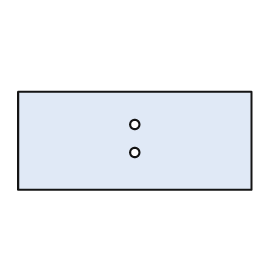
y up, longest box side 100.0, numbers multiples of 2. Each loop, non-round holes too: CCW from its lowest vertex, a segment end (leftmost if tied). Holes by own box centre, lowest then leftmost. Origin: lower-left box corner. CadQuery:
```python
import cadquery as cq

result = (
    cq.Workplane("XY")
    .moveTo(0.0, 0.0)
    .lineTo(100.0, 0.0)
    .lineTo(100.0, 42.0)
    .lineTo(0.0, 42.0)
    .close()
    .moveTo(50.0, 16.0)
    .circle(2.0)
    .moveTo(50.0, 28.0)
    .circle(2.0)
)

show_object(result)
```